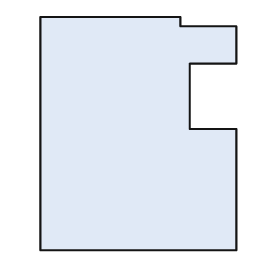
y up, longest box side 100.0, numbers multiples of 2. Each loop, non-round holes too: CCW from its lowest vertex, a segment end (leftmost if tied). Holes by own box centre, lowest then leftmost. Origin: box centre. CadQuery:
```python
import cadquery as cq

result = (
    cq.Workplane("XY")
    .moveTo(-42.0, -50.0)
    .lineTo(42.0, -50.0)
    .lineTo(42.0, 2.0)
    .lineTo(22.0, 2.0)
    .lineTo(22.0, 30.0)
    .lineTo(42.0, 30.0)
    .lineTo(42.0, 46.0)
    .lineTo(18.0, 46.0)
    .lineTo(18.0, 50.0)
    .lineTo(-42.0, 50.0)
    .close()
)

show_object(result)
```